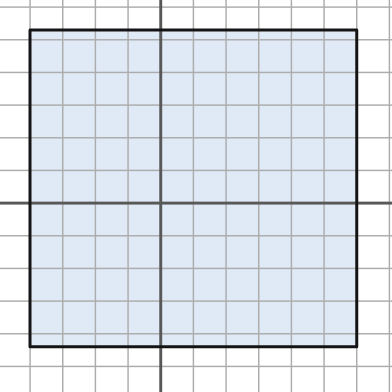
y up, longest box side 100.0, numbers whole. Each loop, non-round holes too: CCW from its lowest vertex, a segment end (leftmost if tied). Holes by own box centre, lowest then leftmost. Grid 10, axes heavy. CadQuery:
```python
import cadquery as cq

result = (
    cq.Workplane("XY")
    .moveTo(-40.0, -44.0)
    .lineTo(60.0, -44.0)
    .lineTo(60.0, 53.0)
    .lineTo(-40.0, 53.0)
    .close()
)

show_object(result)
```